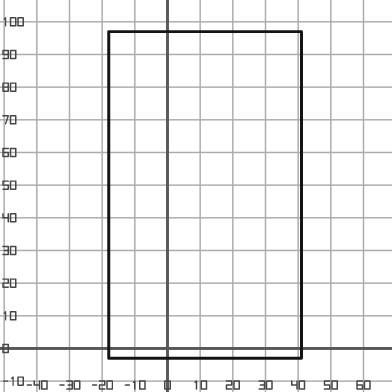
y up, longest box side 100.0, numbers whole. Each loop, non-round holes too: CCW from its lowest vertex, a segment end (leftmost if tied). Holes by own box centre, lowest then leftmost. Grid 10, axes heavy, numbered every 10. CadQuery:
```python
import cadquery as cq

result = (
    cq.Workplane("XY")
    .moveTo(-18.0, -3.0)
    .lineTo(41.0, -3.0)
    .lineTo(41.0, 97.0)
    .lineTo(-18.0, 97.0)
    .close()
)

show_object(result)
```